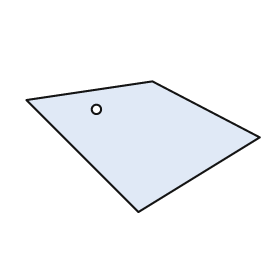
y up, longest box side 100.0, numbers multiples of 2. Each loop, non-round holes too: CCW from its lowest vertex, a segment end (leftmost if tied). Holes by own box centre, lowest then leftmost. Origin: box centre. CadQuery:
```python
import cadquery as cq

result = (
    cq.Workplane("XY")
    .moveTo(-2.0, -28.0)
    .lineTo(50.0, 4.0)
    .lineTo(4.0, 28.0)
    .lineTo(-50.0, 20.0)
    .close()
    .moveTo(-20.0, 16.0)
    .circle(2.0)
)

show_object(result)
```